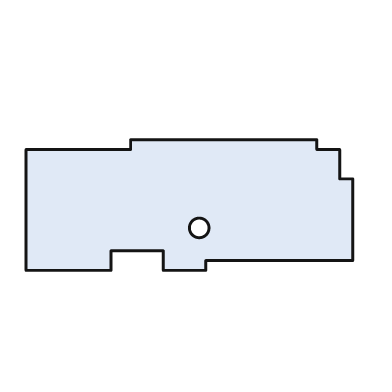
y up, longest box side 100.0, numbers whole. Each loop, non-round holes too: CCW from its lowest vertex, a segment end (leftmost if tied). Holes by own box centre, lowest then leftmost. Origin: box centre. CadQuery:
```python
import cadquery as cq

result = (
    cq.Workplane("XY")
    .moveTo(-50.0, -20.0)
    .lineTo(-24.0, -20.0)
    .lineTo(-24.0, -14.0)
    .lineTo(-8.0, -14.0)
    .lineTo(-8.0, -20.0)
    .lineTo(5.0, -20.0)
    .lineTo(5.0, -17.0)
    .lineTo(50.0, -17.0)
    .lineTo(50.0, 8.0)
    .lineTo(46.0, 8.0)
    .lineTo(46.0, 17.0)
    .lineTo(39.0, 17.0)
    .lineTo(39.0, 20.0)
    .lineTo(-18.0, 20.0)
    .lineTo(-18.0, 17.0)
    .lineTo(-50.0, 17.0)
    .close()
    .moveTo(3.0, -7.0)
    .circle(3.0)
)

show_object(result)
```